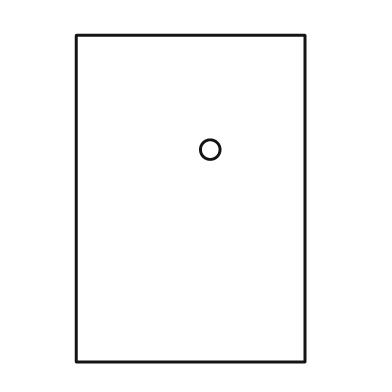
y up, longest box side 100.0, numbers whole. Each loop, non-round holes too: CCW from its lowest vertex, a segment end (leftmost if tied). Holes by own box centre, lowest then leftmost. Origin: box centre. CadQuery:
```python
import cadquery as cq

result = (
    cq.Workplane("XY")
    .moveTo(-35.0, -50.0)
    .lineTo(35.0, -50.0)
    .lineTo(35.0, 50.0)
    .lineTo(-35.0, 50.0)
    .close()
    .moveTo(6.0, 15.0)
    .circle(3.0)
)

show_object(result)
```